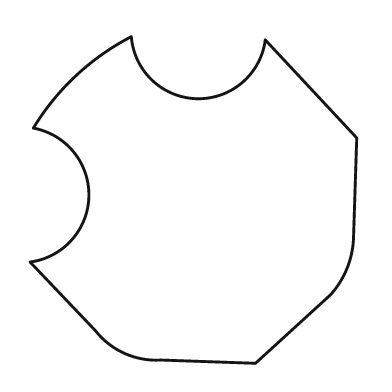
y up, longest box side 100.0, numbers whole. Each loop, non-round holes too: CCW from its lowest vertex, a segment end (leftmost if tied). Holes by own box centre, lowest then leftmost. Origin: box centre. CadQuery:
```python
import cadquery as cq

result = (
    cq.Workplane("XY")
    .moveTo(19.0, -50.0)
    .lineTo(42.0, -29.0)
    .threePointArc((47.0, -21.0), (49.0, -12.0))
    .lineTo(50.0, 19.0)
    .lineTo(22.0, 49.0)
    .threePointArc((1.0, 31.0), (-19.0, 50.0))
    .threePointArc((-36.0, 38.0), (-49.0, 22.0))
    .threePointArc((-32.0, 1.0), (-50.0, -19.0))
    .lineTo(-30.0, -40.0)
    .threePointArc((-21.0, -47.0), (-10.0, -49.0))
    .close()
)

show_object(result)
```